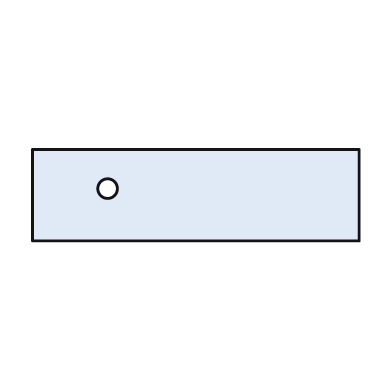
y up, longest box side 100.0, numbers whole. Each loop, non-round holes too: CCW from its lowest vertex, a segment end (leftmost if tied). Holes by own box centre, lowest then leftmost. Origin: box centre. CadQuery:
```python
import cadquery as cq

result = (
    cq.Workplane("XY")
    .moveTo(-50.0, -14.0)
    .lineTo(50.0, -14.0)
    .lineTo(50.0, 14.0)
    .lineTo(-50.0, 14.0)
    .close()
    .moveTo(-27.0, 2.0)
    .circle(3.0)
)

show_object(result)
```